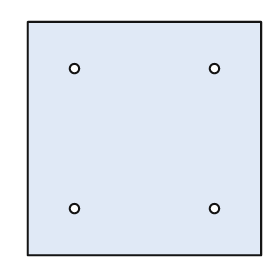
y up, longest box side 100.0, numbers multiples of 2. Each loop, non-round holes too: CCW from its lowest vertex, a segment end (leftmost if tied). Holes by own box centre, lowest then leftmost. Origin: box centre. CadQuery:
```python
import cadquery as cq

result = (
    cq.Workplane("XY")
    .moveTo(-50.0, -50.0)
    .lineTo(50.0, -50.0)
    .lineTo(50.0, 50.0)
    .lineTo(-50.0, 50.0)
    .close()
    .moveTo(-30.0, -30.0)
    .circle(2.0)
    .moveTo(30.0, -30.0)
    .circle(2.0)
    .moveTo(-30.0, 30.0)
    .circle(2.0)
    .moveTo(30.0, 30.0)
    .circle(2.0)
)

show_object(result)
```